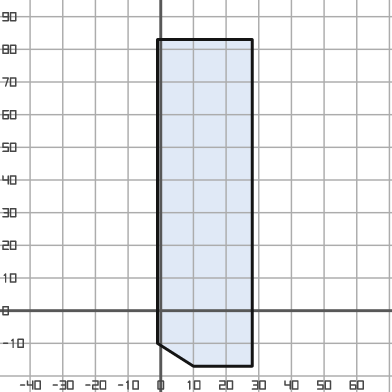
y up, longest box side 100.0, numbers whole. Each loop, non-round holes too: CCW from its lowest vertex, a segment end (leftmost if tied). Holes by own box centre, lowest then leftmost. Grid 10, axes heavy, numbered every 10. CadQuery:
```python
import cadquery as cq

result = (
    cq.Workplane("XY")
    .moveTo(10.0, -17.0)
    .lineTo(28.0, -17.0)
    .lineTo(28.0, 83.0)
    .lineTo(-1.0, 83.0)
    .lineTo(-1.0, -10.0)
    .close()
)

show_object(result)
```